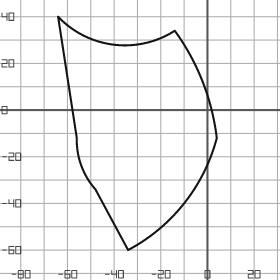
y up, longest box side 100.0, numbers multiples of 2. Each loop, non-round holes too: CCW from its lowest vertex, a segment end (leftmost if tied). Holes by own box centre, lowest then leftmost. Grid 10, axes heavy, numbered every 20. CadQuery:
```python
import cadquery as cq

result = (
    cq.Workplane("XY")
    .moveTo(-34.0, -60.0)
    .threePointArc((-10.0, -40.0), (4.0, -12.0))
    .threePointArc((-2.0, 12.0), (-14.0, 34.0))
    .threePointArc((-40.0, 28.0), (-64.0, 40.0))
    .lineTo(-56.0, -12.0)
    .threePointArc((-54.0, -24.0), (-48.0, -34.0))
    .close()
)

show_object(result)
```